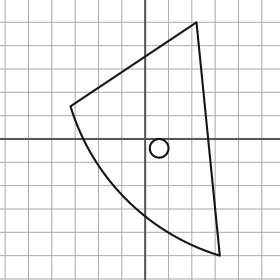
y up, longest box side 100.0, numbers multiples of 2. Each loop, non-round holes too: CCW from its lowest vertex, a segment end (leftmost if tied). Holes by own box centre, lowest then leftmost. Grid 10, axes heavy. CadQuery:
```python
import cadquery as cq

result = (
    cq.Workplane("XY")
    .moveTo(32.0, -50.0)
    .lineTo(22.0, 50.0)
    .lineTo(-32.0, 14.0)
    .threePointArc((-8.0, -26.0), (32.0, -50.0))
    .close()
    .moveTo(6.0, -4.0)
    .circle(4.0)
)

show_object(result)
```